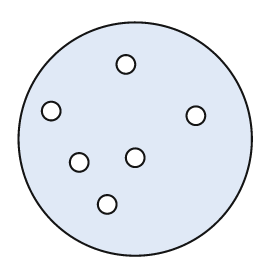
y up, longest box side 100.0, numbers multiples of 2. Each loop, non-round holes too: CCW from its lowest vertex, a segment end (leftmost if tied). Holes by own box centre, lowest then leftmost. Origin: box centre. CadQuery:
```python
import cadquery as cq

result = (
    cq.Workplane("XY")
    .moveTo(0.0, 0.0)
    .circle(50.0)
    .moveTo(-12.0, -28.0)
    .circle(4.0)
    .moveTo(-24.0, -10.0)
    .circle(4.0)
    .moveTo(0.0, -8.0)
    .circle(4.0)
    .moveTo(26.0, 10.0)
    .circle(4.0)
    .moveTo(-36.0, 12.0)
    .circle(4.0)
    .moveTo(-4.0, 32.0)
    .circle(4.0)
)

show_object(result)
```